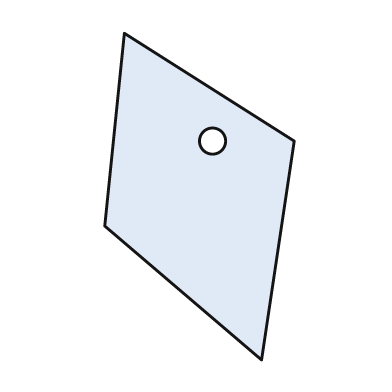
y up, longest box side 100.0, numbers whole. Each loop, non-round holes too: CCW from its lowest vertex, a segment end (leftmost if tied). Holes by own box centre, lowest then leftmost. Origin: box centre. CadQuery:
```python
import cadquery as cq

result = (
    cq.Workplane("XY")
    .moveTo(19.0, -50.0)
    .lineTo(29.0, 17.0)
    .lineTo(-23.0, 50.0)
    .lineTo(-29.0, -9.0)
    .close()
    .moveTo(4.0, 17.0)
    .circle(4.0)
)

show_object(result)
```